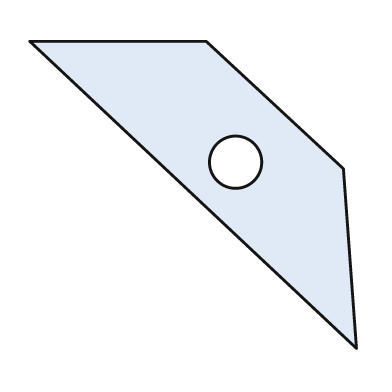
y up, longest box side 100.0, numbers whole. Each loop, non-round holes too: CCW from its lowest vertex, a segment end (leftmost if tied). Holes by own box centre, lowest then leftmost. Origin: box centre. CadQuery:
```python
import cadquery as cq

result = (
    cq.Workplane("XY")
    .moveTo(50.0, -47.0)
    .lineTo(46.0, 8.0)
    .lineTo(4.0, 47.0)
    .lineTo(-50.0, 47.0)
    .close()
    .moveTo(13.0, 10.0)
    .circle(8.0)
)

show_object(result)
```